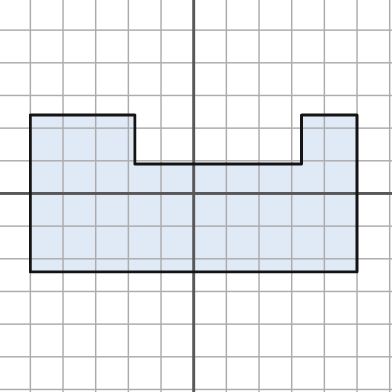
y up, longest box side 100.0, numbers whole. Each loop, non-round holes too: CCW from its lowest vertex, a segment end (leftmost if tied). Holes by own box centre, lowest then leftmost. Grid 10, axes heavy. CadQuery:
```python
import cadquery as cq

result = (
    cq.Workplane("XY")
    .moveTo(-50.0, -24.0)
    .lineTo(50.0, -24.0)
    .lineTo(50.0, 24.0)
    .lineTo(33.0, 24.0)
    .lineTo(33.0, 9.0)
    .lineTo(-18.0, 9.0)
    .lineTo(-18.0, 24.0)
    .lineTo(-50.0, 24.0)
    .close()
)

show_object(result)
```